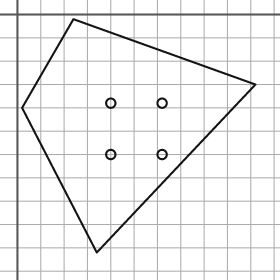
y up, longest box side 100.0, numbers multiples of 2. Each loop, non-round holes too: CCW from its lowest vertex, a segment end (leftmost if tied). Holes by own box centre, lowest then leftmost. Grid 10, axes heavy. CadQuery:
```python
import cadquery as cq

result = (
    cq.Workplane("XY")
    .moveTo(34.0, -102.0)
    .lineTo(102.0, -30.0)
    .lineTo(24.0, -2.0)
    .lineTo(2.0, -40.0)
    .close()
    .moveTo(40.0, -60.0)
    .circle(2.0)
    .moveTo(62.0, -60.0)
    .circle(2.0)
    .moveTo(40.0, -38.0)
    .circle(2.0)
    .moveTo(62.0, -38.0)
    .circle(2.0)
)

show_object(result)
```